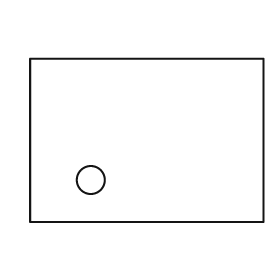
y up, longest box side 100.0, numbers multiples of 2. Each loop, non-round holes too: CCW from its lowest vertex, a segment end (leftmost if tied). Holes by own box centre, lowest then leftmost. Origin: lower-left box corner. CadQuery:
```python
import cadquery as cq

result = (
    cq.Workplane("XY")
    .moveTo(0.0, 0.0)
    .lineTo(100.0, 0.0)
    .lineTo(100.0, 70.0)
    .lineTo(0.0, 70.0)
    .close()
    .moveTo(26.0, 18.0)
    .circle(6.0)
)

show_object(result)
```